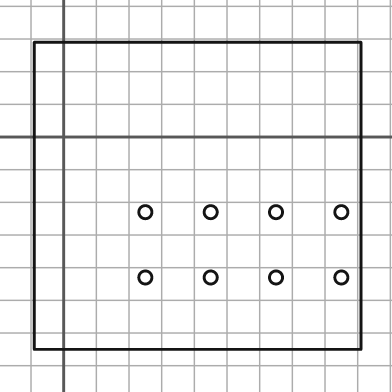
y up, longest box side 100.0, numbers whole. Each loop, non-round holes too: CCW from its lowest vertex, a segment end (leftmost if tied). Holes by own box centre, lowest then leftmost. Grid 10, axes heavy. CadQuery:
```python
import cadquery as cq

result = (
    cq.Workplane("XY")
    .moveTo(-9.0, -65.0)
    .lineTo(91.0, -65.0)
    .lineTo(91.0, 29.0)
    .lineTo(-9.0, 29.0)
    .close()
    .moveTo(25.0, -43.0)
    .circle(2.0)
    .moveTo(45.0, -43.0)
    .circle(2.0)
    .moveTo(65.0, -43.0)
    .circle(2.0)
    .moveTo(85.0, -43.0)
    .circle(2.0)
    .moveTo(25.0, -23.0)
    .circle(2.0)
    .moveTo(45.0, -23.0)
    .circle(2.0)
    .moveTo(65.0, -23.0)
    .circle(2.0)
    .moveTo(85.0, -23.0)
    .circle(2.0)
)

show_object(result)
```